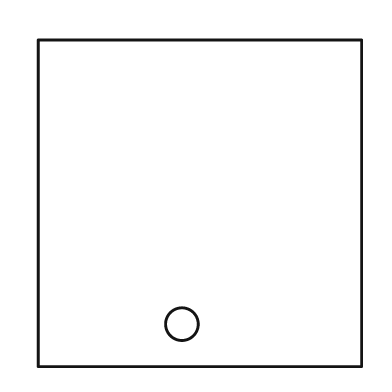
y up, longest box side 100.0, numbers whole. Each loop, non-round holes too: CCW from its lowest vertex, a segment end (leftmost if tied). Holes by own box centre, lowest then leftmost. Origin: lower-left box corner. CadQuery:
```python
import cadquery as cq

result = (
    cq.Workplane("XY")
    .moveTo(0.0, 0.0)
    .lineTo(99.0, 0.0)
    .lineTo(99.0, 100.0)
    .lineTo(0.0, 100.0)
    .close()
    .moveTo(44.0, 13.0)
    .circle(5.0)
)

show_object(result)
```